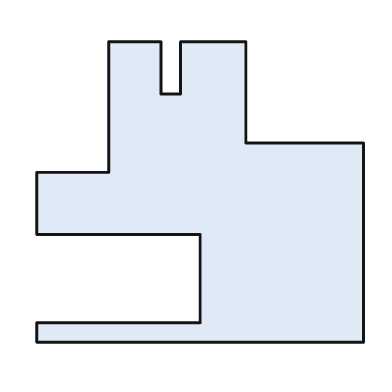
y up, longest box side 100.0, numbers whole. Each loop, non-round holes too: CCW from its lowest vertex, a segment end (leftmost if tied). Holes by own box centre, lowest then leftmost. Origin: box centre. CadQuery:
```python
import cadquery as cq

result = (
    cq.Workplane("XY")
    .moveTo(-50.0, -46.0)
    .lineTo(50.0, -46.0)
    .lineTo(50.0, 15.0)
    .lineTo(14.0, 15.0)
    .lineTo(14.0, 46.0)
    .lineTo(-6.0, 46.0)
    .lineTo(-6.0, 30.0)
    .lineTo(-12.0, 30.0)
    .lineTo(-12.0, 46.0)
    .lineTo(-28.0, 46.0)
    .lineTo(-28.0, 6.0)
    .lineTo(-50.0, 6.0)
    .lineTo(-50.0, -13.0)
    .lineTo(0.0, -13.0)
    .lineTo(0.0, -40.0)
    .lineTo(-50.0, -40.0)
    .close()
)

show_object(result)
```